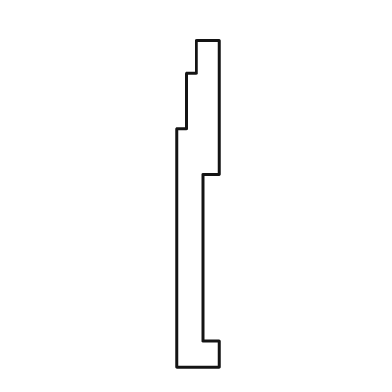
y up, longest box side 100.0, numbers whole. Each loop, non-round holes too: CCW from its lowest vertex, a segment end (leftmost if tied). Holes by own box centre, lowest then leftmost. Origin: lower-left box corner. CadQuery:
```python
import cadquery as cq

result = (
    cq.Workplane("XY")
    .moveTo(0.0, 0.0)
    .lineTo(13.0, 0.0)
    .lineTo(13.0, 8.0)
    .lineTo(8.0, 8.0)
    .lineTo(8.0, 59.0)
    .lineTo(13.0, 59.0)
    .lineTo(13.0, 100.0)
    .lineTo(6.0, 100.0)
    .lineTo(6.0, 90.0)
    .lineTo(3.0, 90.0)
    .lineTo(3.0, 73.0)
    .lineTo(0.0, 73.0)
    .close()
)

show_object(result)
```